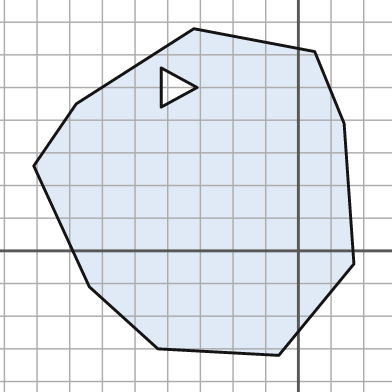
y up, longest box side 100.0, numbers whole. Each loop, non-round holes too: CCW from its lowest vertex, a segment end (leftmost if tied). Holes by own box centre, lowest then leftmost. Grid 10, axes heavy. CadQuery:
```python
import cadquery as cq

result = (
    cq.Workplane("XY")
    .moveTo(-6.0, -32.0)
    .lineTo(17.0, -4.0)
    .lineTo(14.0, 39.0)
    .lineTo(5.0, 61.0)
    .lineTo(-32.0, 68.0)
    .lineTo(-68.0, 45.0)
    .lineTo(-81.0, 26.0)
    .lineTo(-64.0, -11.0)
    .lineTo(-43.0, -30.0)
    .close()
    .moveTo(-42.0, 44.0)
    .lineTo(-31.0, 50.0)
    .lineTo(-42.0, 56.0)
    .close()
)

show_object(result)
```